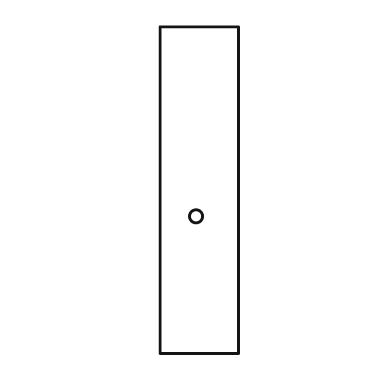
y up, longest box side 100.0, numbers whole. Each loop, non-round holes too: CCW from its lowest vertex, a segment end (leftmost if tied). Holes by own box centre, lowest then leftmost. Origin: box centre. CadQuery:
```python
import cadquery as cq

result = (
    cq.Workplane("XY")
    .moveTo(-12.0, -50.0)
    .lineTo(12.0, -50.0)
    .lineTo(12.0, 50.0)
    .lineTo(-12.0, 50.0)
    .close()
    .moveTo(-1.0, -8.0)
    .circle(2.0)
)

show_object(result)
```